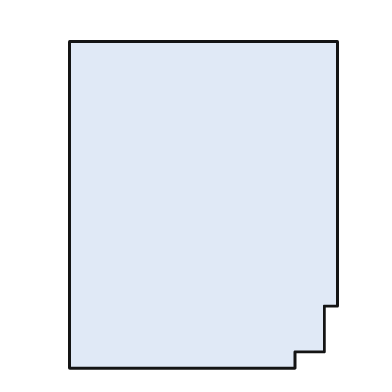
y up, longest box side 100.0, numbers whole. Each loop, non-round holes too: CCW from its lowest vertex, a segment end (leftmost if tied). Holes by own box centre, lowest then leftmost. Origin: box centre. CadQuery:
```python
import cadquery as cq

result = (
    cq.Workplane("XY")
    .moveTo(-41.0, -50.0)
    .lineTo(28.0, -50.0)
    .lineTo(28.0, -45.0)
    .lineTo(37.0, -45.0)
    .lineTo(37.0, -31.0)
    .lineTo(41.0, -31.0)
    .lineTo(41.0, 50.0)
    .lineTo(-41.0, 50.0)
    .close()
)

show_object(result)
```